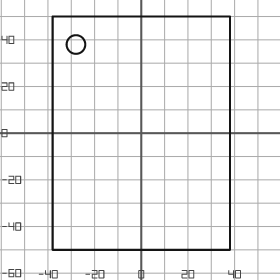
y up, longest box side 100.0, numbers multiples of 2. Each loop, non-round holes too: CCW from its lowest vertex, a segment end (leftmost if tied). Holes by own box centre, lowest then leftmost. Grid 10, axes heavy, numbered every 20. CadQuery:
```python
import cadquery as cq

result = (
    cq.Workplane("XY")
    .moveTo(-38.0, -50.0)
    .lineTo(38.0, -50.0)
    .lineTo(38.0, 50.0)
    .lineTo(-38.0, 50.0)
    .close()
    .moveTo(-28.0, 38.0)
    .circle(4.0)
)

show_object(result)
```